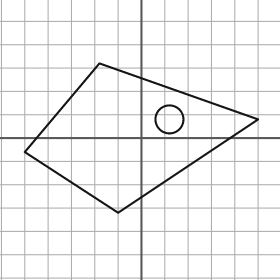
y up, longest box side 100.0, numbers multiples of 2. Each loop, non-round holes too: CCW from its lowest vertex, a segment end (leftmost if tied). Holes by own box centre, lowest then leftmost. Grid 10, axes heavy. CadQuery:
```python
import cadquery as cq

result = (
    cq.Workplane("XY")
    .moveTo(-10.0, -32.0)
    .lineTo(50.0, 8.0)
    .lineTo(-18.0, 32.0)
    .lineTo(-50.0, -6.0)
    .close()
    .moveTo(12.0, 8.0)
    .circle(6.0)
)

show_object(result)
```